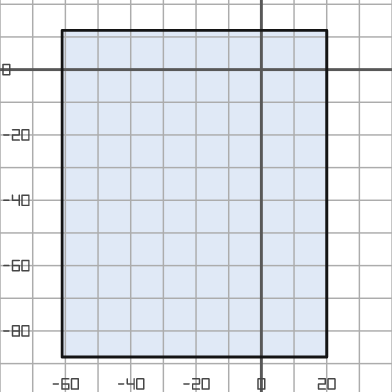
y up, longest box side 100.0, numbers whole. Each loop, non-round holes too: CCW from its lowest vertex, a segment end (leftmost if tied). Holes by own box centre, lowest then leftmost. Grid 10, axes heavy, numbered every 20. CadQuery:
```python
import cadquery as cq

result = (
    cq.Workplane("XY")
    .moveTo(-61.0, -88.0)
    .lineTo(20.0, -88.0)
    .lineTo(20.0, 12.0)
    .lineTo(-61.0, 12.0)
    .close()
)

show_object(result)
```